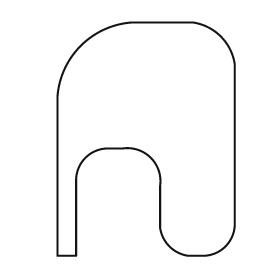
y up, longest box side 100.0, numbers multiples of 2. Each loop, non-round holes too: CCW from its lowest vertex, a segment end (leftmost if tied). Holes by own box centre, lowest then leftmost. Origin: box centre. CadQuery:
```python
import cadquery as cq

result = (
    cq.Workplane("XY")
    .moveTo(-38.0, -50.0)
    .lineTo(-30.0, -50.0)
    .lineTo(-30.0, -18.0)
    .threePointArc((-26.0, -8.0), (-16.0, -4.0))
    .lineTo(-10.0, -4.0)
    .threePointArc((2.0, -8.0), (6.0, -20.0))
    .lineTo(6.0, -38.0)
    .threePointArc((10.0, -46.0), (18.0, -50.0))
    .lineTo(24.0, -50.0)
    .threePointArc((34.0, -46.0), (38.0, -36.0))
    .lineTo(38.0, 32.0)
    .threePointArc((32.0, 44.0), (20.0, 50.0))
    .lineTo(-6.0, 50.0)
    .threePointArc((-28.0, 40.0), (-38.0, 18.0))
    .close()
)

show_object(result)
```